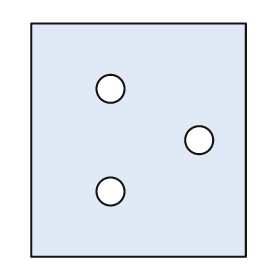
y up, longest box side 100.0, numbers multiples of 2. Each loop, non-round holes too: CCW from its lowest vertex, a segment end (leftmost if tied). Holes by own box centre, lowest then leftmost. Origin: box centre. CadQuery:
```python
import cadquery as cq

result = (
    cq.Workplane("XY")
    .moveTo(-46.0, -50.0)
    .lineTo(46.0, -50.0)
    .lineTo(46.0, 50.0)
    .lineTo(-46.0, 50.0)
    .close()
    .moveTo(-12.0, -22.0)
    .circle(6.0)
    .moveTo(26.0, 0.0)
    .circle(6.0)
    .moveTo(-12.0, 22.0)
    .circle(6.0)
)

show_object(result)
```